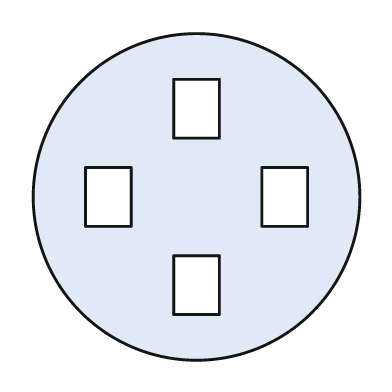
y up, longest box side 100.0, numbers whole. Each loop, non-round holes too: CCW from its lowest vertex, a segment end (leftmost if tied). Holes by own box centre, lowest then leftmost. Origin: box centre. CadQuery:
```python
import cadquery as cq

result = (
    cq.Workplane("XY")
    .moveTo(0.0, 0.0)
    .circle(50.0)
    .moveTo(-7.0, -36.0)
    .lineTo(7.0, -36.0)
    .lineTo(7.0, -18.0)
    .lineTo(-7.0, -18.0)
    .close()
    .moveTo(-34.0, -9.0)
    .lineTo(-20.0, -9.0)
    .lineTo(-20.0, 9.0)
    .lineTo(-34.0, 9.0)
    .close()
    .moveTo(20.0, -9.0)
    .lineTo(34.0, -9.0)
    .lineTo(34.0, 9.0)
    .lineTo(20.0, 9.0)
    .close()
    .moveTo(-7.0, 18.0)
    .lineTo(7.0, 18.0)
    .lineTo(7.0, 36.0)
    .lineTo(-7.0, 36.0)
    .close()
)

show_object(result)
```